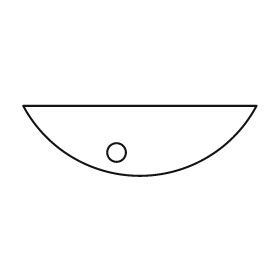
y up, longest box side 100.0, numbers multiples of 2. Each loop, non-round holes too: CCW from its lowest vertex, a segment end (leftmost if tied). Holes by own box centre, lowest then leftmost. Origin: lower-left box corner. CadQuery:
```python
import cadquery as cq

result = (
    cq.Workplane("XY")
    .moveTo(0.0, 30.0)
    .threePointArc((50.0, 0.0), (100.0, 30.0))
    .close()
    .moveTo(40.0, 10.0)
    .circle(4.0)
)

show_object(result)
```